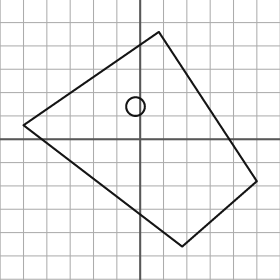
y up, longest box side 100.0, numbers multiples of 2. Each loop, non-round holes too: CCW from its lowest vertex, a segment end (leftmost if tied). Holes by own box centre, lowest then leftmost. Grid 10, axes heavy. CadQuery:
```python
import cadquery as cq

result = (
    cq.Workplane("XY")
    .moveTo(18.0, -46.0)
    .lineTo(50.0, -18.0)
    .lineTo(8.0, 46.0)
    .lineTo(-50.0, 6.0)
    .close()
    .moveTo(-2.0, 14.0)
    .circle(4.0)
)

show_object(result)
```